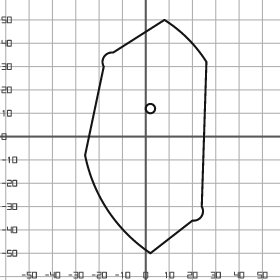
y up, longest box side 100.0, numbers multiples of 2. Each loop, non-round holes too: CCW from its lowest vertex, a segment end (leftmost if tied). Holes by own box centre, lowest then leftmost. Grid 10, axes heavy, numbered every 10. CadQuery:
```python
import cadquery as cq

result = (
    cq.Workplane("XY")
    .moveTo(2.0, -50.0)
    .lineTo(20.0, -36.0)
    .threePointArc((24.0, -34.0), (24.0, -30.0))
    .lineTo(26.0, 32.0)
    .threePointArc((18.0, 42.0), (8.0, 50.0))
    .lineTo(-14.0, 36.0)
    .threePointArc((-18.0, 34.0), (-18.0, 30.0))
    .lineTo(-26.0, -8.0)
    .threePointArc((-16.0, -32.0), (2.0, -50.0))
    .close()
    .moveTo(2.0, 12.0)
    .circle(2.0)
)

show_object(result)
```